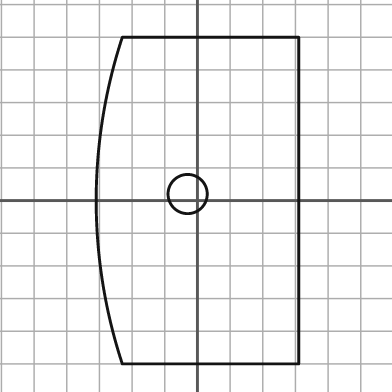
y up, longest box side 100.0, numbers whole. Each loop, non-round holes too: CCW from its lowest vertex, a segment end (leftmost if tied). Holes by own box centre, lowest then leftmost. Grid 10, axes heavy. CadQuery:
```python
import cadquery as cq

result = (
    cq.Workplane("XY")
    .moveTo(-23.0, -50.0)
    .lineTo(31.0, -50.0)
    .lineTo(31.0, 50.0)
    .lineTo(-23.0, 50.0)
    .threePointArc((-31.0, 0.0), (-23.0, -50.0))
    .close()
    .moveTo(-3.0, 2.0)
    .circle(6.0)
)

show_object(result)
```